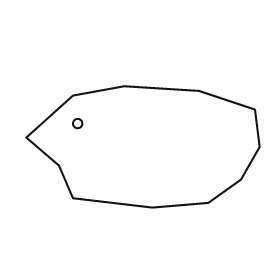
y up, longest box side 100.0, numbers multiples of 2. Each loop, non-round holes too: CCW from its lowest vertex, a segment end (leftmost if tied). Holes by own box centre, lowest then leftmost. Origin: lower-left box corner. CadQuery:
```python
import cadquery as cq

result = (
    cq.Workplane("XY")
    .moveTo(54.0, 0.0)
    .lineTo(78.0, 2.0)
    .lineTo(92.0, 12.0)
    .lineTo(100.0, 26.0)
    .lineTo(98.0, 42.0)
    .lineTo(74.0, 50.0)
    .lineTo(42.0, 52.0)
    .lineTo(20.0, 48.0)
    .lineTo(0.0, 30.0)
    .lineTo(14.0, 18.0)
    .lineTo(20.0, 4.0)
    .close()
    .moveTo(22.0, 36.0)
    .circle(2.0)
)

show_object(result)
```